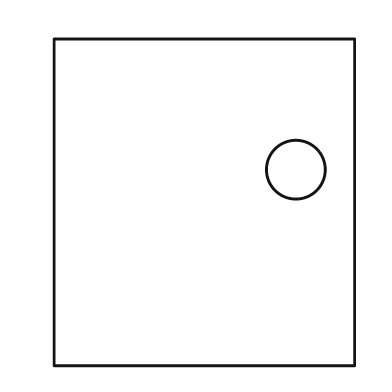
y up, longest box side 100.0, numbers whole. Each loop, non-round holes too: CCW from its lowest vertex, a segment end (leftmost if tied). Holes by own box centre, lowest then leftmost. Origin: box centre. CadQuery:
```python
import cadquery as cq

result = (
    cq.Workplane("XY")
    .moveTo(-46.0, -50.0)
    .lineTo(46.0, -50.0)
    .lineTo(46.0, 50.0)
    .lineTo(-46.0, 50.0)
    .close()
    .moveTo(28.0, 10.0)
    .circle(9.0)
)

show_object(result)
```